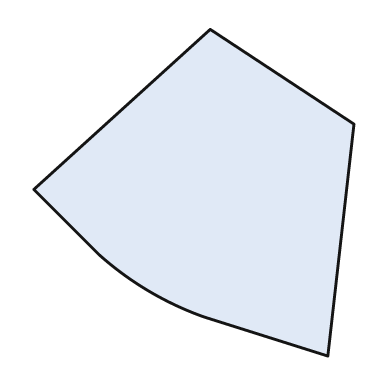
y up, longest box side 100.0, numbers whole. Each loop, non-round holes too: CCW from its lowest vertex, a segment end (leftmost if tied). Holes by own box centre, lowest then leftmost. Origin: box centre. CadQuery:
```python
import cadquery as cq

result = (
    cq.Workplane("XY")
    .moveTo(41.0, -50.0)
    .lineTo(49.0, 21.0)
    .lineTo(5.0, 50.0)
    .lineTo(-49.0, 1.0)
    .lineTo(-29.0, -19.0)
    .threePointArc((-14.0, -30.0), (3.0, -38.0))
    .close()
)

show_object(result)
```